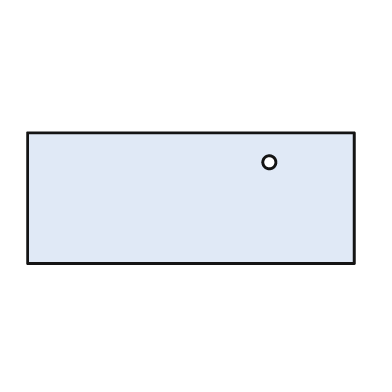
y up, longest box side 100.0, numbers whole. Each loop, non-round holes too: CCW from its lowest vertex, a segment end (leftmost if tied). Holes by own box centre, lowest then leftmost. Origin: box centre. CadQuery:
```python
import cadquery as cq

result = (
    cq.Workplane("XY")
    .moveTo(-50.0, -20.0)
    .lineTo(50.0, -20.0)
    .lineTo(50.0, 20.0)
    .lineTo(-50.0, 20.0)
    .close()
    .moveTo(24.0, 11.0)
    .circle(2.0)
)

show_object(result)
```